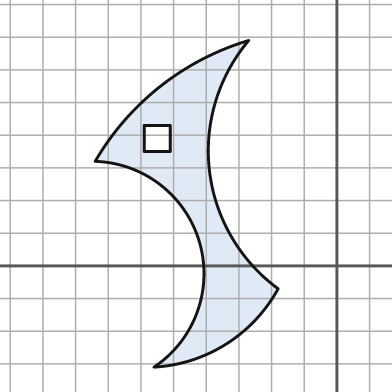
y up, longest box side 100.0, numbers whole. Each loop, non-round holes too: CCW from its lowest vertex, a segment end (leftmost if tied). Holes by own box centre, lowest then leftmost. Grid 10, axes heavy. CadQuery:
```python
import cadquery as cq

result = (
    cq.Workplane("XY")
    .moveTo(-56.0, -31.0)
    .threePointArc((-34.0, -24.0), (-18.0, -7.0))
    .threePointArc((-39.0, 29.0), (-27.0, 69.0))
    .threePointArc((-54.0, 55.0), (-74.0, 32.0))
    .threePointArc((-42.0, 7.0), (-56.0, -31.0))
    .close()
    .moveTo(-59.0, 35.0)
    .lineTo(-51.0, 35.0)
    .lineTo(-51.0, 43.0)
    .lineTo(-59.0, 43.0)
    .close()
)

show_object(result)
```